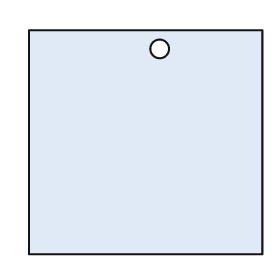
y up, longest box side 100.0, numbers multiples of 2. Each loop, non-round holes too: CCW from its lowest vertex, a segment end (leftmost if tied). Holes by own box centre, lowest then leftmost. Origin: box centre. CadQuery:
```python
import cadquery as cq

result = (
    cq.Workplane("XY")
    .moveTo(-50.0, -48.0)
    .lineTo(50.0, -48.0)
    .lineTo(50.0, 48.0)
    .lineTo(-50.0, 48.0)
    .close()
    .moveTo(6.0, 40.0)
    .circle(4.0)
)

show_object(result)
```